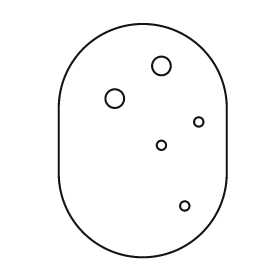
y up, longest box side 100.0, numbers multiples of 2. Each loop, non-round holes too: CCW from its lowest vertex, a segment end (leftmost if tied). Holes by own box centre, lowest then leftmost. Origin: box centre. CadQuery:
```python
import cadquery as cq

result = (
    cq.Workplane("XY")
    .moveTo(-36.0, -14.0)
    .threePointArc((0.0, -50.0), (36.0, -14.0))
    .lineTo(36.0, 14.0)
    .threePointArc((0.0, 50.0), (-36.0, 14.0))
    .close()
    .moveTo(18.0, -28.0)
    .circle(2.0)
    .moveTo(8.0, -2.0)
    .circle(2.0)
    .moveTo(24.0, 8.0)
    .circle(2.0)
    .moveTo(-12.0, 18.0)
    .circle(4.0)
    .moveTo(8.0, 32.0)
    .circle(4.0)
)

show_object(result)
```